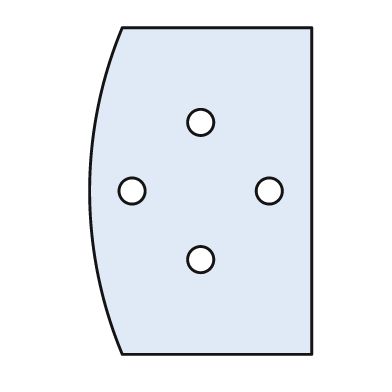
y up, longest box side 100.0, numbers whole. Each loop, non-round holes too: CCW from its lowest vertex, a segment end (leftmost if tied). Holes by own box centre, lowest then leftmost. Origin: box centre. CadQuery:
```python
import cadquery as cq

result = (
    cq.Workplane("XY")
    .moveTo(-24.0, -50.0)
    .lineTo(34.0, -50.0)
    .lineTo(34.0, 50.0)
    .lineTo(-24.0, 50.0)
    .threePointArc((-34.0, 0.0), (-24.0, -50.0))
    .close()
    .moveTo(0.0, -21.0)
    .circle(4.0)
    .moveTo(-21.0, 0.0)
    .circle(4.0)
    .moveTo(21.0, 0.0)
    .circle(4.0)
    .moveTo(0.0, 21.0)
    .circle(4.0)
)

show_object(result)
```